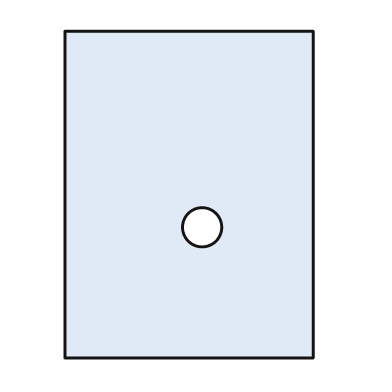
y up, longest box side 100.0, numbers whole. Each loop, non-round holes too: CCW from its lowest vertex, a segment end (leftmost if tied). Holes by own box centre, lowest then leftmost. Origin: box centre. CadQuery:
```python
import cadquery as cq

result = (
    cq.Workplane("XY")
    .moveTo(-38.0, -50.0)
    .lineTo(38.0, -50.0)
    .lineTo(38.0, 50.0)
    .lineTo(-38.0, 50.0)
    .close()
    .moveTo(4.0, -10.0)
    .circle(6.0)
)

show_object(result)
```